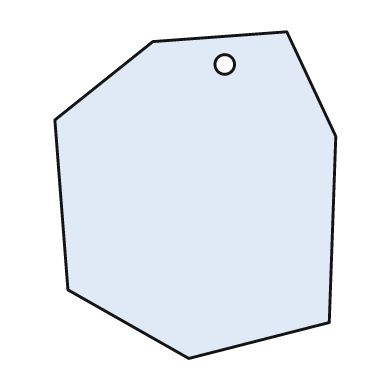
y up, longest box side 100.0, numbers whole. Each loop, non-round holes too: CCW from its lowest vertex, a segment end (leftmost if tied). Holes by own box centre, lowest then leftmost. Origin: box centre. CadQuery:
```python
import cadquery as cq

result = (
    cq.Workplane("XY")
    .moveTo(-2.0, -50.0)
    .lineTo(41.0, -39.0)
    .lineTo(43.0, 18.0)
    .lineTo(28.0, 50.0)
    .lineTo(-13.0, 47.0)
    .lineTo(-43.0, 23.0)
    .lineTo(-39.0, -29.0)
    .close()
    .moveTo(9.0, 40.0)
    .circle(3.0)
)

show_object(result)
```